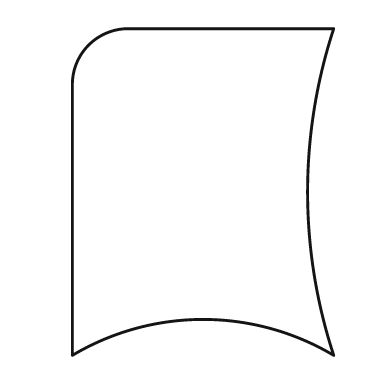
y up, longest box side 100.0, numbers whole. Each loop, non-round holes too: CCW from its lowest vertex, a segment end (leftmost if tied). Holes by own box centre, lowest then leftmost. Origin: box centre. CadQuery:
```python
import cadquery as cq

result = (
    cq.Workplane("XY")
    .moveTo(-40.0, -50.0)
    .threePointArc((0.0, -39.0), (40.0, -50.0))
    .threePointArc((32.0, 0.0), (40.0, 50.0))
    .lineTo(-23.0, 50.0)
    .threePointArc((-35.0, 45.0), (-40.0, 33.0))
    .close()
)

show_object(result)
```